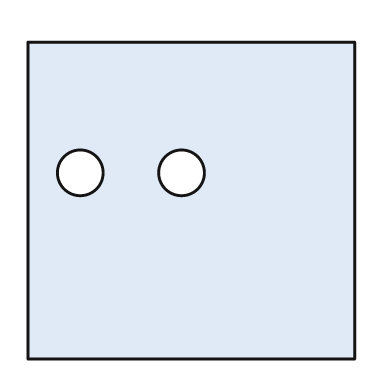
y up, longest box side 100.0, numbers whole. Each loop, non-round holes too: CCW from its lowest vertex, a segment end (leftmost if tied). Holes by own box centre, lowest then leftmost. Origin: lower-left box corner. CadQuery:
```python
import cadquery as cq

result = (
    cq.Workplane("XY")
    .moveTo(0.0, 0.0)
    .lineTo(100.0, 0.0)
    .lineTo(100.0, 97.0)
    .lineTo(0.0, 97.0)
    .close()
    .moveTo(16.0, 57.0)
    .circle(7.0)
    .moveTo(47.0, 57.0)
    .circle(7.0)
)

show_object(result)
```